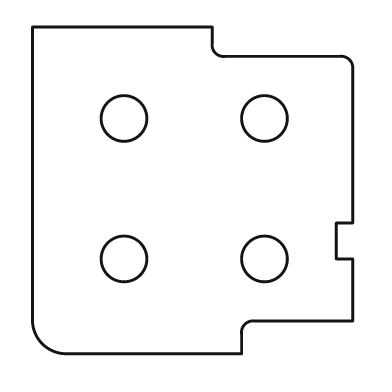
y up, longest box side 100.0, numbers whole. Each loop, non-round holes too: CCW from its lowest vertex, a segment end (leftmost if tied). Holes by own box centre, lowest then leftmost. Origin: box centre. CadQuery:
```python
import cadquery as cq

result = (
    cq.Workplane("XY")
    .moveTo(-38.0, -50.0)
    .lineTo(15.0, -50.0)
    .lineTo(15.0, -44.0)
    .threePointArc((16.0, -41.0), (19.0, -40.0))
    .lineTo(49.0, -40.0)
    .lineTo(49.0, -21.0)
    .lineTo(44.0, -21.0)
    .lineTo(44.0, -10.0)
    .lineTo(49.0, -10.0)
    .lineTo(49.0, 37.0)
    .threePointArc((48.0, 40.0), (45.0, 41.0))
    .lineTo(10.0, 41.0)
    .threePointArc((7.0, 42.0), (6.0, 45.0))
    .lineTo(6.0, 50.0)
    .lineTo(-49.0, 50.0)
    .lineTo(-49.0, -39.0)
    .threePointArc((-46.0, -47.0), (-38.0, -50.0))
    .close()
    .moveTo(-21.0, -21.0)
    .circle(7.0)
    .moveTo(22.0, -21.0)
    .circle(7.0)
    .moveTo(-21.0, 22.0)
    .circle(7.0)
    .moveTo(22.0, 22.0)
    .circle(7.0)
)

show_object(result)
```